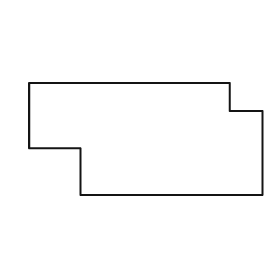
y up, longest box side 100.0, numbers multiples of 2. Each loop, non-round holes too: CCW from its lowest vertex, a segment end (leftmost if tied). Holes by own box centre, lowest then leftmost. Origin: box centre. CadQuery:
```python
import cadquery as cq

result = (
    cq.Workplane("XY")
    .moveTo(-28.0, -24.0)
    .lineTo(50.0, -24.0)
    .lineTo(50.0, 12.0)
    .lineTo(36.0, 12.0)
    .lineTo(36.0, 24.0)
    .lineTo(-50.0, 24.0)
    .lineTo(-50.0, -4.0)
    .lineTo(-28.0, -4.0)
    .close()
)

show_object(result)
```